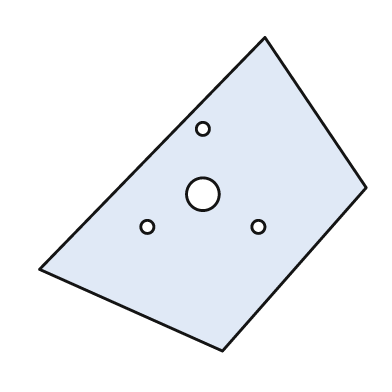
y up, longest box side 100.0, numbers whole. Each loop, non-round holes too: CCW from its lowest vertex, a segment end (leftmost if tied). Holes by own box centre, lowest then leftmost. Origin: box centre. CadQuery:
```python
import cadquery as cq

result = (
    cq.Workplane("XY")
    .moveTo(6.0, -48.0)
    .lineTo(50.0, 2.0)
    .lineTo(19.0, 48.0)
    .lineTo(-50.0, -23.0)
    .close()
    .moveTo(-17.0, -10.0)
    .circle(2.0)
    .moveTo(17.0, -10.0)
    .circle(2.0)
    .moveTo(0.0, 0.0)
    .circle(5.0)
    .moveTo(0.0, 20.0)
    .circle(2.0)
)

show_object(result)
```